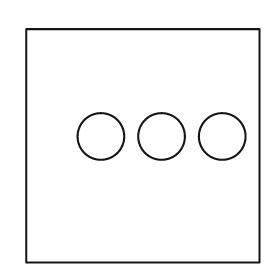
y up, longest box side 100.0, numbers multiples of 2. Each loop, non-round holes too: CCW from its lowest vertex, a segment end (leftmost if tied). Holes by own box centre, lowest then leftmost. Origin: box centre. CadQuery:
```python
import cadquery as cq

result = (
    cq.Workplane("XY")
    .moveTo(-50.0, -50.0)
    .lineTo(50.0, -50.0)
    .lineTo(50.0, 50.0)
    .lineTo(-50.0, 50.0)
    .close()
    .moveTo(-18.0, 4.0)
    .circle(10.0)
    .moveTo(8.0, 4.0)
    .circle(10.0)
    .moveTo(34.0, 4.0)
    .circle(10.0)
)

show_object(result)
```